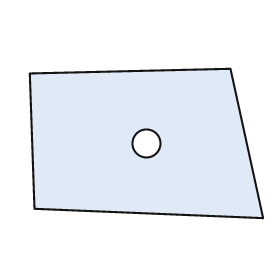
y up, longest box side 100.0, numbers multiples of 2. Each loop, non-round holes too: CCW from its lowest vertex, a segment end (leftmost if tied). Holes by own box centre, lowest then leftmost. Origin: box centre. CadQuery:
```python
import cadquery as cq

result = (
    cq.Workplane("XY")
    .moveTo(50.0, -32.0)
    .lineTo(36.0, 32.0)
    .lineTo(-50.0, 30.0)
    .lineTo(-48.0, -28.0)
    .close()
    .moveTo(0.0, 0.0)
    .circle(6.0)
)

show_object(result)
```